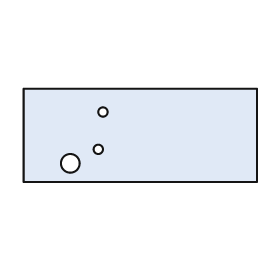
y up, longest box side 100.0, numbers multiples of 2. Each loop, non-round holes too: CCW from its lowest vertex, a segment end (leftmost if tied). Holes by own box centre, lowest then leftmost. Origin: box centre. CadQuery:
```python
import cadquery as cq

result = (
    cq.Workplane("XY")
    .moveTo(-50.0, -20.0)
    .lineTo(50.0, -20.0)
    .lineTo(50.0, 20.0)
    .lineTo(-50.0, 20.0)
    .close()
    .moveTo(-30.0, -12.0)
    .circle(4.0)
    .moveTo(-18.0, -6.0)
    .circle(2.0)
    .moveTo(-16.0, 10.0)
    .circle(2.0)
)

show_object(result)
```